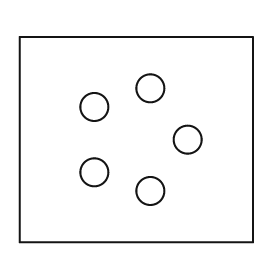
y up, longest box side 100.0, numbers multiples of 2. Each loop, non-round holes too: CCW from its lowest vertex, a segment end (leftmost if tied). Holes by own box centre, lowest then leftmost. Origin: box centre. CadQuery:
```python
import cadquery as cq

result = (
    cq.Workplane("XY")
    .moveTo(-50.0, -44.0)
    .lineTo(50.0, -44.0)
    .lineTo(50.0, 44.0)
    .lineTo(-50.0, 44.0)
    .close()
    .moveTo(6.0, -22.0)
    .circle(6.0)
    .moveTo(-18.0, -14.0)
    .circle(6.0)
    .moveTo(22.0, 0.0)
    .circle(6.0)
    .moveTo(-18.0, 14.0)
    .circle(6.0)
    .moveTo(6.0, 22.0)
    .circle(6.0)
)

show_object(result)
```